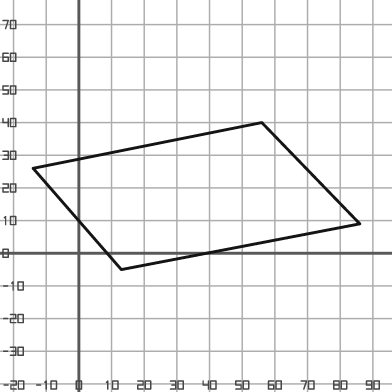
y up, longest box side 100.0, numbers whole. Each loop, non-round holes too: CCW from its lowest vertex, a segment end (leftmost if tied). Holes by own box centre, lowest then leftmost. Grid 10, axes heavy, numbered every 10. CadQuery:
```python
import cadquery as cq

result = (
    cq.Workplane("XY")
    .moveTo(13.0, -5.0)
    .lineTo(86.0, 9.0)
    .lineTo(56.0, 40.0)
    .lineTo(-14.0, 26.0)
    .close()
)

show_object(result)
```